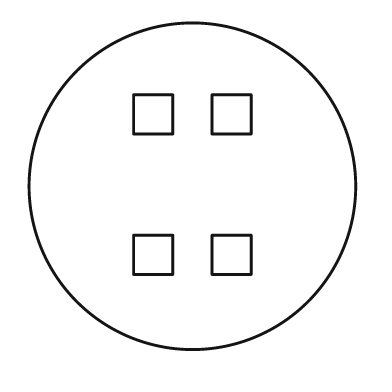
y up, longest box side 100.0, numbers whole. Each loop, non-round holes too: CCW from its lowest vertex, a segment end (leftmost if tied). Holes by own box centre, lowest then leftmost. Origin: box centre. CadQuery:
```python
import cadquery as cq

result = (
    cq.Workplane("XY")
    .moveTo(0.0, 0.0)
    .circle(50.0)
    .moveTo(-18.0, -27.0)
    .lineTo(-6.0, -27.0)
    .lineTo(-6.0, -15.0)
    .lineTo(-18.0, -15.0)
    .close()
    .moveTo(6.0, -27.0)
    .lineTo(18.0, -27.0)
    .lineTo(18.0, -15.0)
    .lineTo(6.0, -15.0)
    .close()
    .moveTo(-18.0, 16.0)
    .lineTo(-6.0, 16.0)
    .lineTo(-6.0, 28.0)
    .lineTo(-18.0, 28.0)
    .close()
    .moveTo(6.0, 16.0)
    .lineTo(18.0, 16.0)
    .lineTo(18.0, 28.0)
    .lineTo(6.0, 28.0)
    .close()
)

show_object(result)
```